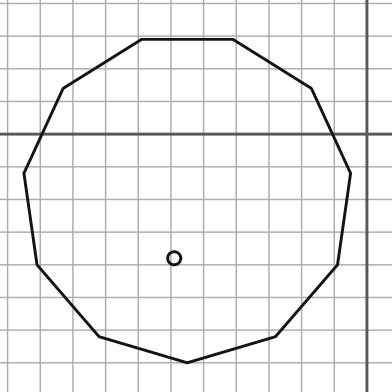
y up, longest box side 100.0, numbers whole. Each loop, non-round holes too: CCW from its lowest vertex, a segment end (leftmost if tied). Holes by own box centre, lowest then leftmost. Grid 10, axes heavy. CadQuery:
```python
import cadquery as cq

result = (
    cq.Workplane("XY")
    .moveTo(-55.0, -70.0)
    .lineTo(-28.0, -62.0)
    .lineTo(-9.0, -40.0)
    .lineTo(-5.0, -12.0)
    .lineTo(-17.0, 14.0)
    .lineTo(-41.0, 29.0)
    .lineTo(-69.0, 29.0)
    .lineTo(-93.0, 14.0)
    .lineTo(-105.0, -12.0)
    .lineTo(-101.0, -40.0)
    .lineTo(-82.0, -62.0)
    .close()
    .moveTo(-59.0, -38.0)
    .circle(2.0)
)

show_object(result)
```